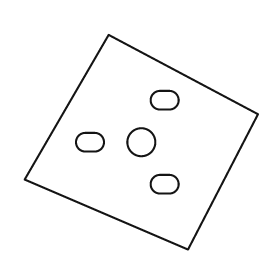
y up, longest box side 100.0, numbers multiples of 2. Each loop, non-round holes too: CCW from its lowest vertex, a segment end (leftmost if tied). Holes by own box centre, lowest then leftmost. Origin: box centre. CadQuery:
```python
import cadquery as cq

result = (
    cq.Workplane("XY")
    .moveTo(20.0, -46.0)
    .lineTo(50.0, 12.0)
    .lineTo(-14.0, 46.0)
    .lineTo(-50.0, -16.0)
    .close()
    .moveTo(8.0, -22.0)
    .lineTo(12.0, -22.0)
    .threePointArc((16.0, -18.0), (12.0, -14.0))
    .lineTo(8.0, -14.0)
    .threePointArc((4.0, -18.0), (8.0, -22.0))
    .close()
    .moveTo(-24.0, -4.0)
    .lineTo(-20.0, -4.0)
    .threePointArc((-16.0, 0.0), (-20.0, 4.0))
    .lineTo(-24.0, 4.0)
    .threePointArc((-28.0, 0.0), (-24.0, -4.0))
    .close()
    .moveTo(0.0, 0.0)
    .circle(6.0)
    .moveTo(8.0, 14.0)
    .lineTo(12.0, 14.0)
    .threePointArc((16.0, 18.0), (12.0, 22.0))
    .lineTo(8.0, 22.0)
    .threePointArc((4.0, 18.0), (8.0, 14.0))
    .close()
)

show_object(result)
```